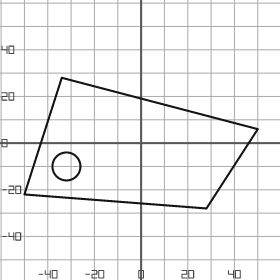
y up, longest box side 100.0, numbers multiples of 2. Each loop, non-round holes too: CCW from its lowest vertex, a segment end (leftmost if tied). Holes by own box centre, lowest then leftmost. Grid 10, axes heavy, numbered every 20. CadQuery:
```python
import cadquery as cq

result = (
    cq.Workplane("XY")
    .moveTo(28.0, -28.0)
    .lineTo(50.0, 6.0)
    .lineTo(-34.0, 28.0)
    .lineTo(-50.0, -22.0)
    .close()
    .moveTo(-32.0, -10.0)
    .circle(6.0)
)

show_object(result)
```